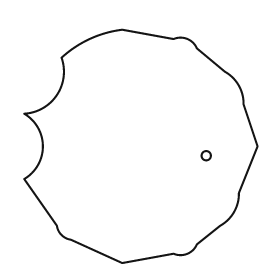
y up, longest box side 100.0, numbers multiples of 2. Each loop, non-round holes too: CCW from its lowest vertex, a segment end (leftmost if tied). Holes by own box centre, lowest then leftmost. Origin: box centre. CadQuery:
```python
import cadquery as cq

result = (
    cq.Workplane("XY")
    .moveTo(-8.0, -50.0)
    .lineTo(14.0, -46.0)
    .threePointArc((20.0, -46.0), (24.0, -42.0))
    .lineTo(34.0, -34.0)
    .threePointArc((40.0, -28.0), (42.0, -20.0))
    .lineTo(50.0, 0.0)
    .lineTo(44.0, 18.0)
    .threePointArc((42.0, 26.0), (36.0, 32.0))
    .lineTo(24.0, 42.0)
    .threePointArc((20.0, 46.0), (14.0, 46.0))
    .lineTo(-8.0, 50.0)
    .threePointArc((-22.0, 46.0), (-34.0, 38.0))
    .threePointArc((-36.0, 22.0), (-50.0, 14.0))
    .threePointArc((-42.0, 0.0), (-50.0, -14.0))
    .lineTo(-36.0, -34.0)
    .threePointArc((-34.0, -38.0), (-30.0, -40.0))
    .close()
    .moveTo(28.0, -4.0)
    .circle(2.0)
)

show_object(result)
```